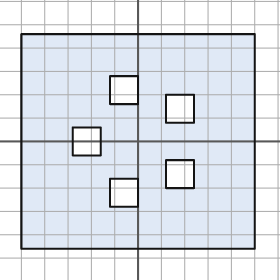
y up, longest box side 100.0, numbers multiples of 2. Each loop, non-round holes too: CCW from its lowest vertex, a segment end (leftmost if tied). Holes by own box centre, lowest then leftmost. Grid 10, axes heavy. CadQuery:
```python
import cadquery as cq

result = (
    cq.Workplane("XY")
    .moveTo(-50.0, -46.0)
    .lineTo(50.0, -46.0)
    .lineTo(50.0, 46.0)
    .lineTo(-50.0, 46.0)
    .close()
    .moveTo(-12.0, -28.0)
    .lineTo(0.0, -28.0)
    .lineTo(0.0, -16.0)
    .lineTo(-12.0, -16.0)
    .close()
    .moveTo(12.0, -20.0)
    .lineTo(24.0, -20.0)
    .lineTo(24.0, -8.0)
    .lineTo(12.0, -8.0)
    .close()
    .moveTo(-28.0, -6.0)
    .lineTo(-16.0, -6.0)
    .lineTo(-16.0, 6.0)
    .lineTo(-28.0, 6.0)
    .close()
    .moveTo(12.0, 8.0)
    .lineTo(24.0, 8.0)
    .lineTo(24.0, 20.0)
    .lineTo(12.0, 20.0)
    .close()
    .moveTo(-12.0, 16.0)
    .lineTo(0.0, 16.0)
    .lineTo(0.0, 28.0)
    .lineTo(-12.0, 28.0)
    .close()
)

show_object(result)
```